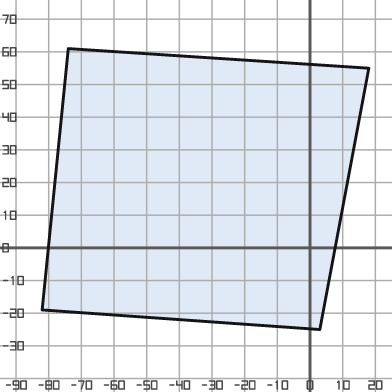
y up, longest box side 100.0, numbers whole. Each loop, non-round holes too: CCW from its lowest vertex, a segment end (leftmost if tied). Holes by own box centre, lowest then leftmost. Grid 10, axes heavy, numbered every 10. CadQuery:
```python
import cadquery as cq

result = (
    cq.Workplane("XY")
    .moveTo(3.0, -25.0)
    .lineTo(18.0, 55.0)
    .lineTo(-74.0, 61.0)
    .lineTo(-82.0, -19.0)
    .close()
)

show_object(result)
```